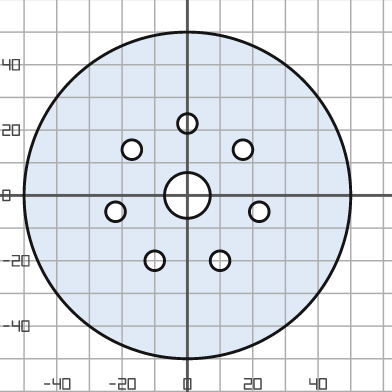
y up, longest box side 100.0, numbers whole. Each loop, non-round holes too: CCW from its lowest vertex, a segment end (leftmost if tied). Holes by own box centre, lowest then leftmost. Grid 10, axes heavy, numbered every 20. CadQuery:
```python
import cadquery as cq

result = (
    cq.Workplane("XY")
    .moveTo(0.0, 0.0)
    .circle(50.0)
    .moveTo(-10.0, -20.0)
    .circle(3.0)
    .moveTo(10.0, -20.0)
    .circle(3.0)
    .moveTo(-22.0, -5.0)
    .circle(3.0)
    .moveTo(22.0, -5.0)
    .circle(3.0)
    .moveTo(0.0, 0.0)
    .circle(7.0)
    .moveTo(-17.0, 14.0)
    .circle(3.0)
    .moveTo(17.0, 14.0)
    .circle(3.0)
    .moveTo(0.0, 22.0)
    .circle(3.0)
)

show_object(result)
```